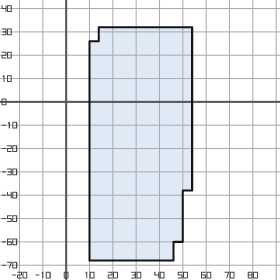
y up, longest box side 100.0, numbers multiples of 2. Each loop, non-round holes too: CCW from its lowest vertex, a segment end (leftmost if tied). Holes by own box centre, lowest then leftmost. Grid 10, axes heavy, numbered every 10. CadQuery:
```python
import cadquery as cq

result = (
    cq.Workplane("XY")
    .moveTo(10.0, -68.0)
    .lineTo(46.0, -68.0)
    .lineTo(46.0, -60.0)
    .lineTo(50.0, -60.0)
    .lineTo(50.0, -38.0)
    .lineTo(54.0, -38.0)
    .lineTo(54.0, 32.0)
    .lineTo(14.0, 32.0)
    .lineTo(14.0, 26.0)
    .lineTo(10.0, 26.0)
    .close()
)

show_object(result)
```